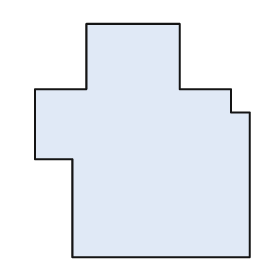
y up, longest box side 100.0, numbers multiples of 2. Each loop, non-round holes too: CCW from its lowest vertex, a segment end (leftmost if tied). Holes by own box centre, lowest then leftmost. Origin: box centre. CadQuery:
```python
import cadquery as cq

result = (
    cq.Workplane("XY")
    .moveTo(-30.0, -50.0)
    .lineTo(46.0, -50.0)
    .lineTo(46.0, 12.0)
    .lineTo(38.0, 12.0)
    .lineTo(38.0, 22.0)
    .lineTo(16.0, 22.0)
    .lineTo(16.0, 50.0)
    .lineTo(-24.0, 50.0)
    .lineTo(-24.0, 22.0)
    .lineTo(-46.0, 22.0)
    .lineTo(-46.0, -8.0)
    .lineTo(-30.0, -8.0)
    .close()
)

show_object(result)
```